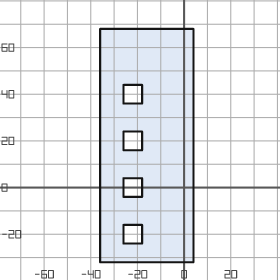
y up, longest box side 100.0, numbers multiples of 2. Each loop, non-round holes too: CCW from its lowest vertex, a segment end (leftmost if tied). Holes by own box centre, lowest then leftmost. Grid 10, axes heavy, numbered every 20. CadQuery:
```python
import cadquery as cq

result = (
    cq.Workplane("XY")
    .moveTo(-36.0, -32.0)
    .lineTo(4.0, -32.0)
    .lineTo(4.0, 68.0)
    .lineTo(-36.0, 68.0)
    .close()
    .moveTo(-26.0, -24.0)
    .lineTo(-18.0, -24.0)
    .lineTo(-18.0, -16.0)
    .lineTo(-26.0, -16.0)
    .close()
    .moveTo(-26.0, -4.0)
    .lineTo(-18.0, -4.0)
    .lineTo(-18.0, 4.0)
    .lineTo(-26.0, 4.0)
    .close()
    .moveTo(-26.0, 16.0)
    .lineTo(-18.0, 16.0)
    .lineTo(-18.0, 24.0)
    .lineTo(-26.0, 24.0)
    .close()
    .moveTo(-26.0, 36.0)
    .lineTo(-18.0, 36.0)
    .lineTo(-18.0, 44.0)
    .lineTo(-26.0, 44.0)
    .close()
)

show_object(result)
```